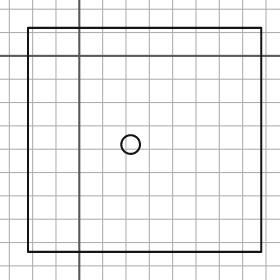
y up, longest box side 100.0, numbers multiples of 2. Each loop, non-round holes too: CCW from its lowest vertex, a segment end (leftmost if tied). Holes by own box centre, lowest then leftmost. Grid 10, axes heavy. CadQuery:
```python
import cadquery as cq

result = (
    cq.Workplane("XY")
    .moveTo(-22.0, -84.0)
    .lineTo(78.0, -84.0)
    .lineTo(78.0, 12.0)
    .lineTo(-22.0, 12.0)
    .close()
    .moveTo(22.0, -38.0)
    .circle(4.0)
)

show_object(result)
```